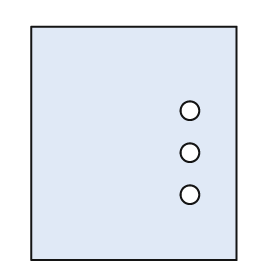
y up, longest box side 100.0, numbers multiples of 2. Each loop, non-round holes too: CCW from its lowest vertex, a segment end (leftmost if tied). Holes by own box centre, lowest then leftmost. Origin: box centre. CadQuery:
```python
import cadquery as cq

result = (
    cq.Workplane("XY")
    .moveTo(-44.0, -50.0)
    .lineTo(44.0, -50.0)
    .lineTo(44.0, 50.0)
    .lineTo(-44.0, 50.0)
    .close()
    .moveTo(24.0, -22.0)
    .circle(4.0)
    .moveTo(24.0, -4.0)
    .circle(4.0)
    .moveTo(24.0, 14.0)
    .circle(4.0)
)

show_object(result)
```